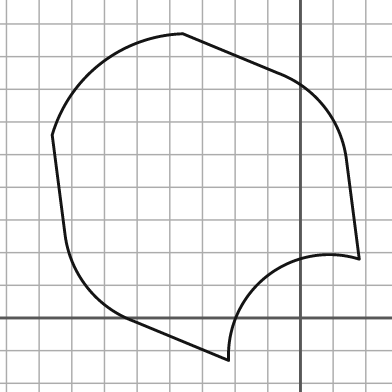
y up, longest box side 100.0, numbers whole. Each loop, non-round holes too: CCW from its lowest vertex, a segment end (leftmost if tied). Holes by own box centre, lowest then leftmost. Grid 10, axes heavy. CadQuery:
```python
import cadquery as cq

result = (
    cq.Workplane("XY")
    .moveTo(-22.0, -13.0)
    .threePointArc((-10.0, 13.0), (18.0, 18.0))
    .lineTo(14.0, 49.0)
    .threePointArc((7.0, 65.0), (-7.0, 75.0))
    .lineTo(-36.0, 87.0)
    .threePointArc((-61.0, 78.0), (-76.0, 56.0))
    .lineTo(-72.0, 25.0)
    .threePointArc((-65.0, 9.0), (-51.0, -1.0))
    .close()
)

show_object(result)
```